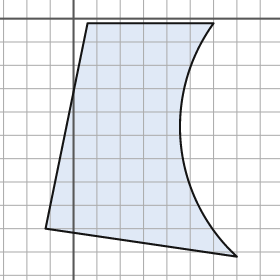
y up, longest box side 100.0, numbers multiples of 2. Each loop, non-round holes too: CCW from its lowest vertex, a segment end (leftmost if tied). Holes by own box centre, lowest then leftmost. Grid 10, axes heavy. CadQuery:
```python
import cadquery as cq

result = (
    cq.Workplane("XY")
    .moveTo(70.0, -102.0)
    .threePointArc((46.0, -54.0), (60.0, -2.0))
    .lineTo(6.0, -2.0)
    .lineTo(-12.0, -90.0)
    .close()
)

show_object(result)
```